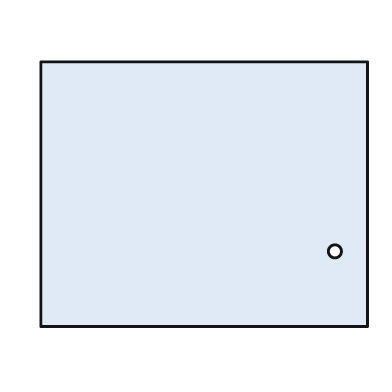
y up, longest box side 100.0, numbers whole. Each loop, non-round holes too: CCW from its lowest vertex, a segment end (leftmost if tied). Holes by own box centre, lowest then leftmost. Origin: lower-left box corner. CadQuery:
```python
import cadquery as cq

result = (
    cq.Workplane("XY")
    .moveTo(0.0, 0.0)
    .lineTo(100.0, 0.0)
    .lineTo(100.0, 81.0)
    .lineTo(0.0, 81.0)
    .close()
    .moveTo(90.0, 23.0)
    .circle(2.0)
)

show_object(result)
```